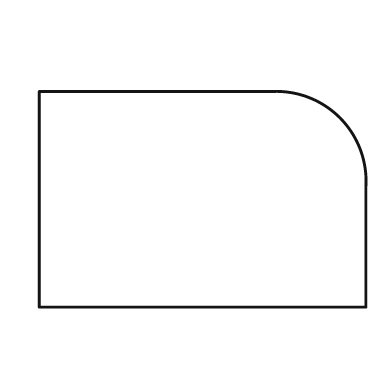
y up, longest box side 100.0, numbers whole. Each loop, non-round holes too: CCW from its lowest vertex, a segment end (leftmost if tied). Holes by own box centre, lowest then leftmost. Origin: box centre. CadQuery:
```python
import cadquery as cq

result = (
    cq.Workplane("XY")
    .moveTo(-50.0, -33.0)
    .lineTo(50.0, -33.0)
    .lineTo(50.0, 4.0)
    .threePointArc((42.0, 25.0), (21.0, 33.0))
    .lineTo(-50.0, 33.0)
    .close()
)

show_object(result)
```